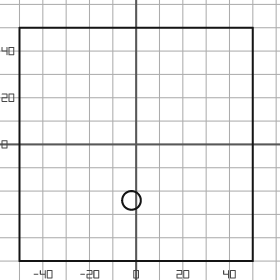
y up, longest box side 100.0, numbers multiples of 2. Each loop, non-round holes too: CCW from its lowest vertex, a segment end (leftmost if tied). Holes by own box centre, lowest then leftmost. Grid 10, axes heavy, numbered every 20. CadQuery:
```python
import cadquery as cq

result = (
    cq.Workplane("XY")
    .moveTo(-50.0, -50.0)
    .lineTo(50.0, -50.0)
    .lineTo(50.0, 50.0)
    .lineTo(-50.0, 50.0)
    .close()
    .moveTo(-2.0, -24.0)
    .circle(4.0)
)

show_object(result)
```